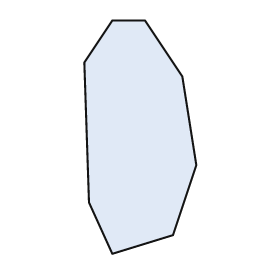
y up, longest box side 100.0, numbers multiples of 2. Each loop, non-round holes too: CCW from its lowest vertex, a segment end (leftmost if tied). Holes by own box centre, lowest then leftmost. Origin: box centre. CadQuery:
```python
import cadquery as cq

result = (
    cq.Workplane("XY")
    .moveTo(-12.0, -50.0)
    .lineTo(14.0, -42.0)
    .lineTo(24.0, -12.0)
    .lineTo(18.0, 26.0)
    .lineTo(2.0, 50.0)
    .lineTo(-12.0, 50.0)
    .lineTo(-24.0, 32.0)
    .lineTo(-22.0, -28.0)
    .close()
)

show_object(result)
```